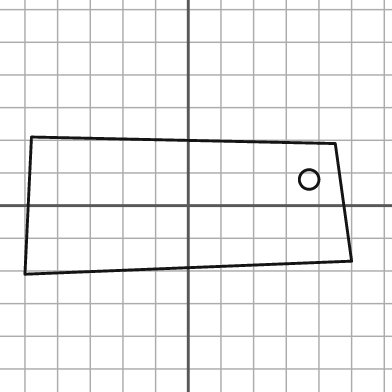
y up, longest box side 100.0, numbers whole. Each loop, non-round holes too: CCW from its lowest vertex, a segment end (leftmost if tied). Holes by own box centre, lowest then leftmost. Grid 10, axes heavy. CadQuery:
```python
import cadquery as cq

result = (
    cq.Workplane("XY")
    .moveTo(-50.0, -21.0)
    .lineTo(50.0, -17.0)
    .lineTo(45.0, 19.0)
    .lineTo(-48.0, 21.0)
    .close()
    .moveTo(37.0, 8.0)
    .circle(3.0)
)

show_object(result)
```